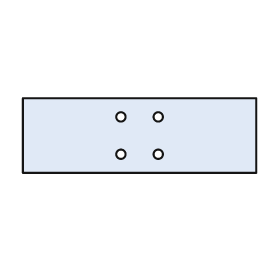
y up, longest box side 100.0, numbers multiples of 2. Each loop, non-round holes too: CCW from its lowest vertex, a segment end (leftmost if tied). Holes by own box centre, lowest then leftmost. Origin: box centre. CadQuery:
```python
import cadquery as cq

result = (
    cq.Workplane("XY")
    .moveTo(-50.0, -16.0)
    .lineTo(50.0, -16.0)
    .lineTo(50.0, 16.0)
    .lineTo(-50.0, 16.0)
    .close()
    .moveTo(-8.0, -8.0)
    .circle(2.0)
    .moveTo(8.0, -8.0)
    .circle(2.0)
    .moveTo(-8.0, 8.0)
    .circle(2.0)
    .moveTo(8.0, 8.0)
    .circle(2.0)
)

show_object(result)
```